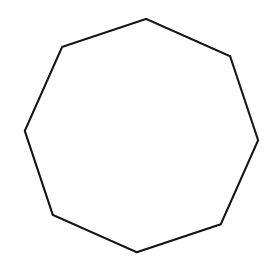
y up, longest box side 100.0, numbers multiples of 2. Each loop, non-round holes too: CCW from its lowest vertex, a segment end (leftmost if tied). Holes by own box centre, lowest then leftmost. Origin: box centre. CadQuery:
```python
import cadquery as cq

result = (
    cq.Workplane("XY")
    .moveTo(-2.0, -50.0)
    .lineTo(34.0, -38.0)
    .lineTo(50.0, -2.0)
    .lineTo(38.0, 34.0)
    .lineTo(2.0, 50.0)
    .lineTo(-34.0, 38.0)
    .lineTo(-50.0, 2.0)
    .lineTo(-38.0, -34.0)
    .close()
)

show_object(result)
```